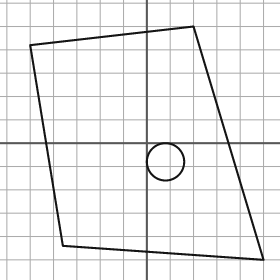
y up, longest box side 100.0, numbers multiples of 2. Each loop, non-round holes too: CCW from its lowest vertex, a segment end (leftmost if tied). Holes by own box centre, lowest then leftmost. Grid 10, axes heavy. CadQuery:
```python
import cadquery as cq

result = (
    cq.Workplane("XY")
    .moveTo(50.0, -50.0)
    .lineTo(20.0, 50.0)
    .lineTo(-50.0, 42.0)
    .lineTo(-36.0, -44.0)
    .close()
    .moveTo(8.0, -8.0)
    .circle(8.0)
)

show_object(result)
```